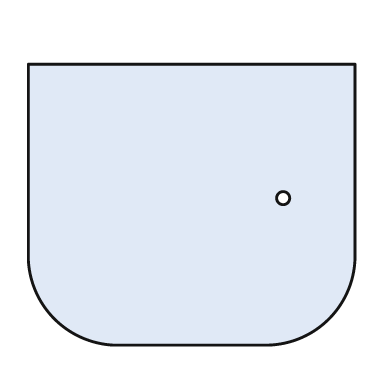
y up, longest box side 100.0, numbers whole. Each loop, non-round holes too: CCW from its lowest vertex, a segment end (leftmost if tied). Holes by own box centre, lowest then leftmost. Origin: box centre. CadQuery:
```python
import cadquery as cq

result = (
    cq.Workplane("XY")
    .moveTo(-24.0, -43.0)
    .lineTo(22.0, -43.0)
    .threePointArc((42.0, -35.0), (50.0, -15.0))
    .lineTo(50.0, 43.0)
    .lineTo(-50.0, 43.0)
    .lineTo(-50.0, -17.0)
    .threePointArc((-42.0, -35.0), (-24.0, -43.0))
    .close()
    .moveTo(28.0, 2.0)
    .circle(2.0)
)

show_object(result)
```